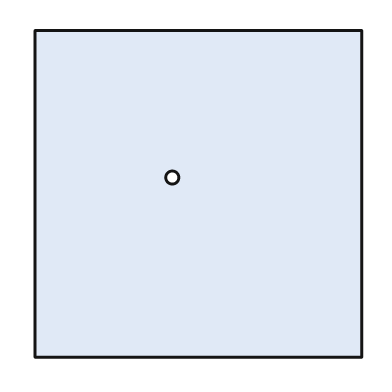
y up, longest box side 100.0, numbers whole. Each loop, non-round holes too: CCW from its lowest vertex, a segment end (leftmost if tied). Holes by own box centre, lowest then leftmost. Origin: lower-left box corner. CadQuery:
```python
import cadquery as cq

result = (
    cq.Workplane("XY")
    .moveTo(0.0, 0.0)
    .lineTo(100.0, 0.0)
    .lineTo(100.0, 100.0)
    .lineTo(0.0, 100.0)
    .close()
    .moveTo(42.0, 55.0)
    .circle(2.0)
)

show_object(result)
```